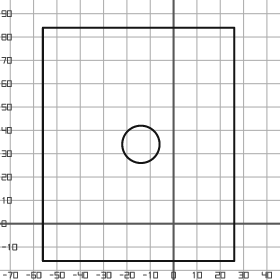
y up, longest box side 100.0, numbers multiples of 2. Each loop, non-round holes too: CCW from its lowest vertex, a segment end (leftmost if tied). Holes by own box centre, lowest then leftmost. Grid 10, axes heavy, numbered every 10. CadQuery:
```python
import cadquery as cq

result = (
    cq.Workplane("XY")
    .moveTo(-56.0, -16.0)
    .lineTo(26.0, -16.0)
    .lineTo(26.0, 84.0)
    .lineTo(-56.0, 84.0)
    .close()
    .moveTo(-14.0, 34.0)
    .circle(8.0)
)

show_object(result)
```